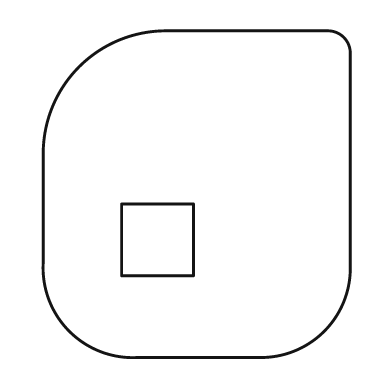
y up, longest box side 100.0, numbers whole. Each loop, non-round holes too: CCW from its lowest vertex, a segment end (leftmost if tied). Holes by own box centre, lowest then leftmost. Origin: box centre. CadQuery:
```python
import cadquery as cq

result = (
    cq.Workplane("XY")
    .moveTo(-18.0, -50.0)
    .lineTo(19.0, -50.0)
    .threePointArc((39.0, -42.0), (47.0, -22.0))
    .lineTo(47.0, 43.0)
    .threePointArc((45.0, 48.0), (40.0, 50.0))
    .lineTo(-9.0, 50.0)
    .threePointArc((-36.0, 39.0), (-47.0, 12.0))
    .lineTo(-47.0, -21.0)
    .threePointArc((-39.0, -42.0), (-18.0, -50.0))
    .close()
    .moveTo(-23.0, -25.0)
    .lineTo(-1.0, -25.0)
    .lineTo(-1.0, -3.0)
    .lineTo(-23.0, -3.0)
    .close()
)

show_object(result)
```